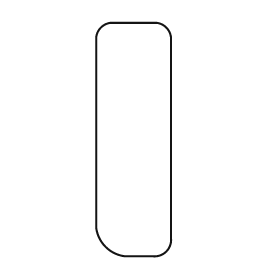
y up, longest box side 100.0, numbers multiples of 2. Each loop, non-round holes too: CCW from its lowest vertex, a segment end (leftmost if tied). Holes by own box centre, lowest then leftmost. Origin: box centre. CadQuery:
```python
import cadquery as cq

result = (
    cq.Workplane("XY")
    .moveTo(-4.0, -50.0)
    .lineTo(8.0, -50.0)
    .threePointArc((14.0, -48.0), (16.0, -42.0))
    .lineTo(16.0, 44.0)
    .threePointArc((14.0, 48.0), (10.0, 50.0))
    .lineTo(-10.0, 50.0)
    .threePointArc((-14.0, 48.0), (-16.0, 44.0))
    .lineTo(-16.0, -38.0)
    .threePointArc((-12.0, -46.0), (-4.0, -50.0))
    .close()
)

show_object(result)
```